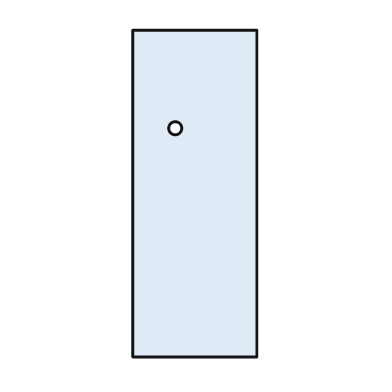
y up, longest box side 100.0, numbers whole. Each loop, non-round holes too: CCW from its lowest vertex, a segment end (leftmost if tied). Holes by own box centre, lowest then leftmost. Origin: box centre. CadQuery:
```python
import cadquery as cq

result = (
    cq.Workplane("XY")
    .moveTo(-19.0, -50.0)
    .lineTo(19.0, -50.0)
    .lineTo(19.0, 50.0)
    .lineTo(-19.0, 50.0)
    .close()
    .moveTo(-6.0, 20.0)
    .circle(2.0)
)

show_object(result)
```